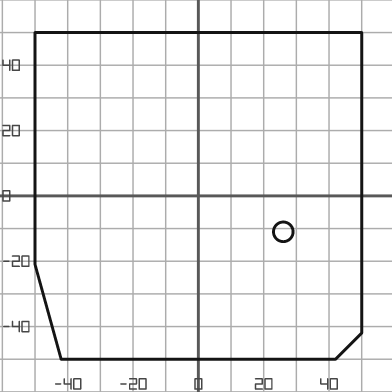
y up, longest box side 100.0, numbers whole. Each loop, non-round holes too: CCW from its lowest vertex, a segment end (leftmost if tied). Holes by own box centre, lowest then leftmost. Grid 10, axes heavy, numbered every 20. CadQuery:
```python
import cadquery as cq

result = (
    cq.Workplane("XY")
    .moveTo(-42.0, -50.0)
    .lineTo(42.0, -50.0)
    .lineTo(50.0, -42.0)
    .lineTo(50.0, 50.0)
    .lineTo(-50.0, 50.0)
    .lineTo(-50.0, -21.0)
    .close()
    .moveTo(26.0, -11.0)
    .circle(3.0)
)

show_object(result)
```